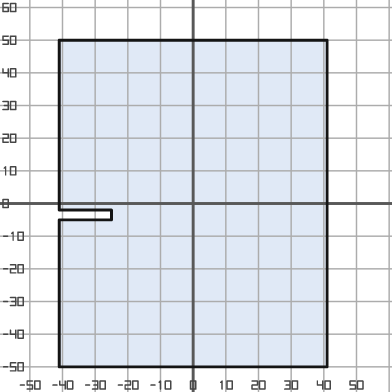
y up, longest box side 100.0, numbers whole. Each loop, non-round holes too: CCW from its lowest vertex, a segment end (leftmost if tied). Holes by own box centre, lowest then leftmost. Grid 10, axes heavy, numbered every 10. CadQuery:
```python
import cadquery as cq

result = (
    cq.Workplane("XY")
    .moveTo(-41.0, -50.0)
    .lineTo(41.0, -50.0)
    .lineTo(41.0, 50.0)
    .lineTo(-41.0, 50.0)
    .lineTo(-41.0, -2.0)
    .lineTo(-25.0, -2.0)
    .lineTo(-25.0, -5.0)
    .lineTo(-41.0, -5.0)
    .close()
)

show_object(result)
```